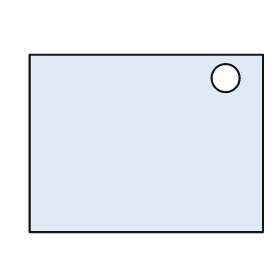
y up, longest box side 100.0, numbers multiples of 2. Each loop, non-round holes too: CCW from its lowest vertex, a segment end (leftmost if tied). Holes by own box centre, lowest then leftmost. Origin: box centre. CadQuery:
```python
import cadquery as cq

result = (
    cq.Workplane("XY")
    .moveTo(-50.0, -38.0)
    .lineTo(50.0, -38.0)
    .lineTo(50.0, 38.0)
    .lineTo(-50.0, 38.0)
    .close()
    .moveTo(34.0, 28.0)
    .circle(6.0)
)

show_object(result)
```